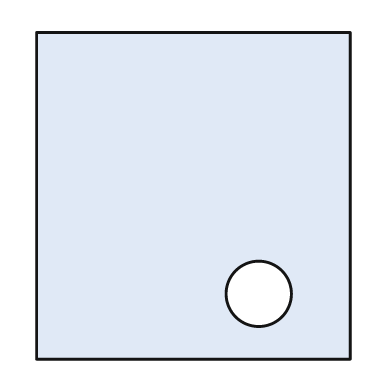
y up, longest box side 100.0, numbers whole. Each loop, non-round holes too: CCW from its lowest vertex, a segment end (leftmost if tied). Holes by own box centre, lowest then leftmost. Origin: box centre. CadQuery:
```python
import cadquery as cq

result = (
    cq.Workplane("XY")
    .moveTo(-48.0, -50.0)
    .lineTo(48.0, -50.0)
    .lineTo(48.0, 50.0)
    .lineTo(-48.0, 50.0)
    .close()
    .moveTo(20.0, -30.0)
    .circle(10.0)
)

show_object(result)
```